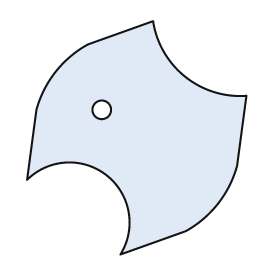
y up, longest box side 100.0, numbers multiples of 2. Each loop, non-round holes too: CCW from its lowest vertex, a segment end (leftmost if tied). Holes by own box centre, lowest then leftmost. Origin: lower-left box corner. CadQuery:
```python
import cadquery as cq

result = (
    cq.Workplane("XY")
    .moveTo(40.0, 0.0)
    .lineTo(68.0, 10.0)
    .threePointArc((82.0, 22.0), (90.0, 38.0))
    .lineTo(94.0, 68.0)
    .threePointArc((68.0, 76.0), (54.0, 100.0))
    .lineTo(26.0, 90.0)
    .threePointArc((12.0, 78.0), (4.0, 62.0))
    .lineTo(0.0, 32.0)
    .threePointArc((34.0, 34.0), (40.0, 0.0))
    .close()
    .moveTo(32.0, 62.0)
    .circle(4.0)
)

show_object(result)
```